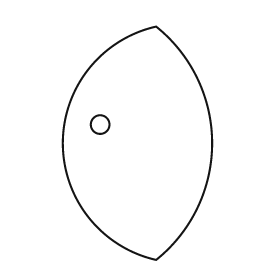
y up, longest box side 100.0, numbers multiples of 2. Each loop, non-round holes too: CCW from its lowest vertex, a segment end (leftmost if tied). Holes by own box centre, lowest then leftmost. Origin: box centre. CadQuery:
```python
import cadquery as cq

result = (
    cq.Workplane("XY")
    .moveTo(8.0, -50.0)
    .threePointArc((32.0, 0.0), (8.0, 50.0))
    .threePointArc((-32.0, 0.0), (8.0, -50.0))
    .close()
    .moveTo(-16.0, 8.0)
    .circle(4.0)
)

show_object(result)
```